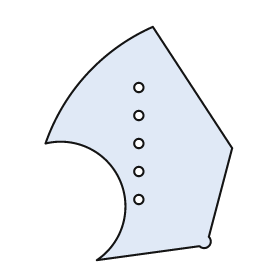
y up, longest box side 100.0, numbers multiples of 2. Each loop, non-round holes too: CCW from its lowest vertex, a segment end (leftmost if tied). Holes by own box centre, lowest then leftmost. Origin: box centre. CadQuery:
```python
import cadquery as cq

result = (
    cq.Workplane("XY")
    .moveTo(-18.0, -50.0)
    .lineTo(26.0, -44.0)
    .threePointArc((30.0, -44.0), (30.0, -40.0))
    .lineTo(40.0, -2.0)
    .lineTo(6.0, 50.0)
    .threePointArc((-22.0, 30.0), (-40.0, 0.0))
    .threePointArc((-8.0, -16.0), (-18.0, -50.0))
    .close()
    .moveTo(0.0, -24.0)
    .circle(2.0)
    .moveTo(0.0, -12.0)
    .circle(2.0)
    .moveTo(0.0, 0.0)
    .circle(2.0)
    .moveTo(0.0, 12.0)
    .circle(2.0)
    .moveTo(0.0, 24.0)
    .circle(2.0)
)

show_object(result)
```